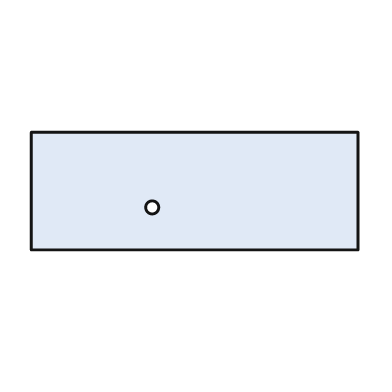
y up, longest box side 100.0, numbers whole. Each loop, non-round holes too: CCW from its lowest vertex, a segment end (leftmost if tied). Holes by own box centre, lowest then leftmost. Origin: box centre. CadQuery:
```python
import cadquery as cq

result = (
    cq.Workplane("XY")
    .moveTo(-50.0, -18.0)
    .lineTo(50.0, -18.0)
    .lineTo(50.0, 18.0)
    .lineTo(-50.0, 18.0)
    .close()
    .moveTo(-13.0, -5.0)
    .circle(2.0)
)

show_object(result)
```